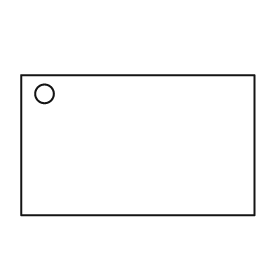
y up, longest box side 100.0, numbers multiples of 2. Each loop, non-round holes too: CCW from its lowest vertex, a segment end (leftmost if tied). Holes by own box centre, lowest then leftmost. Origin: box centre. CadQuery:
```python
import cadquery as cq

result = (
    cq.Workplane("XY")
    .moveTo(-50.0, -30.0)
    .lineTo(50.0, -30.0)
    .lineTo(50.0, 30.0)
    .lineTo(-50.0, 30.0)
    .close()
    .moveTo(-40.0, 22.0)
    .circle(4.0)
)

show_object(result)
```